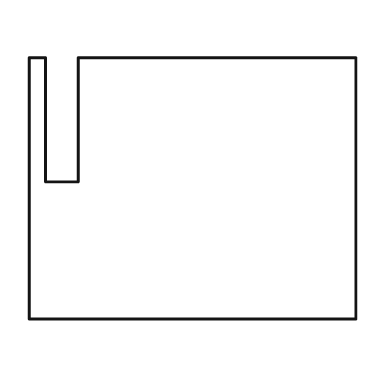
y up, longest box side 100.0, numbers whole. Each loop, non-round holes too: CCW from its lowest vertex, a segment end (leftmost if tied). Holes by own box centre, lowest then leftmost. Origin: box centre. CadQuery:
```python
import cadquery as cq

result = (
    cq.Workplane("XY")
    .moveTo(-50.0, -40.0)
    .lineTo(50.0, -40.0)
    .lineTo(50.0, 40.0)
    .lineTo(-35.0, 40.0)
    .lineTo(-35.0, 2.0)
    .lineTo(-45.0, 2.0)
    .lineTo(-45.0, 40.0)
    .lineTo(-50.0, 40.0)
    .close()
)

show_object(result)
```